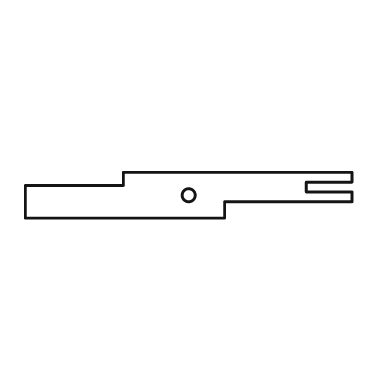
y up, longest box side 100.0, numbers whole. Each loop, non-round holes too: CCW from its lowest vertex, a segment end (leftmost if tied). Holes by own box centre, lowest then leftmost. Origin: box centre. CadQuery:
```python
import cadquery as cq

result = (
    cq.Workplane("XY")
    .moveTo(-50.0, -7.0)
    .lineTo(11.0, -7.0)
    .lineTo(11.0, -2.0)
    .lineTo(50.0, -2.0)
    .lineTo(50.0, 1.0)
    .lineTo(36.0, 1.0)
    .lineTo(36.0, 4.0)
    .lineTo(50.0, 4.0)
    .lineTo(50.0, 7.0)
    .lineTo(-20.0, 7.0)
    .lineTo(-20.0, 3.0)
    .lineTo(-50.0, 3.0)
    .close()
    .moveTo(0.0, 0.0)
    .circle(2.0)
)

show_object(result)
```